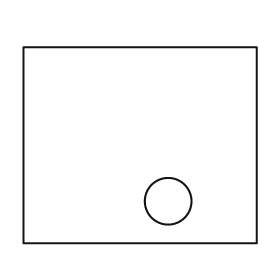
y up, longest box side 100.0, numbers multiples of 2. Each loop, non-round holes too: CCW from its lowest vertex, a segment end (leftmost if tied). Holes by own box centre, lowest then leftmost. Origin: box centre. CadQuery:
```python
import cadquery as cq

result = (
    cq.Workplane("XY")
    .moveTo(-50.0, -42.0)
    .lineTo(50.0, -42.0)
    .lineTo(50.0, 42.0)
    .lineTo(-50.0, 42.0)
    .close()
    .moveTo(12.0, -24.0)
    .circle(10.0)
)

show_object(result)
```